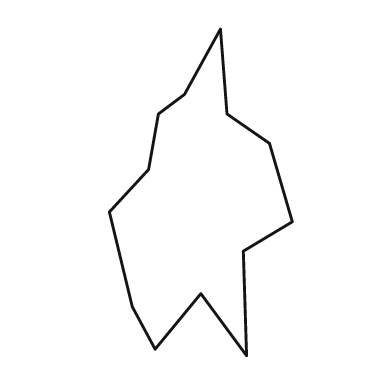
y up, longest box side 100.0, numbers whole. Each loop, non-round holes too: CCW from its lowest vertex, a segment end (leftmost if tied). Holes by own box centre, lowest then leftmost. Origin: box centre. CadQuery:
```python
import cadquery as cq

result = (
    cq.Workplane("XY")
    .moveTo(14.0, -50.0)
    .lineTo(13.0, -18.0)
    .lineTo(28.0, -9.0)
    .lineTo(21.0, 15.0)
    .lineTo(8.0, 24.0)
    .lineTo(6.0, 50.0)
    .lineTo(-5.0, 30.0)
    .lineTo(-13.0, 24.0)
    .lineTo(-16.0, 7.0)
    .lineTo(-28.0, -6.0)
    .lineTo(-21.0, -35.0)
    .lineTo(-14.0, -48.0)
    .lineTo(0.0, -31.0)
    .close()
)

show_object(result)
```